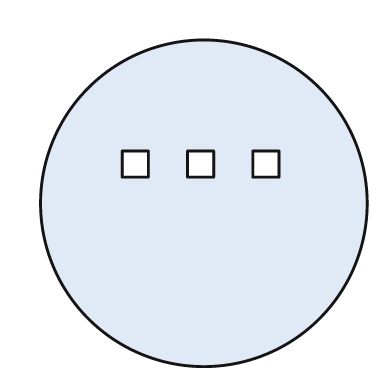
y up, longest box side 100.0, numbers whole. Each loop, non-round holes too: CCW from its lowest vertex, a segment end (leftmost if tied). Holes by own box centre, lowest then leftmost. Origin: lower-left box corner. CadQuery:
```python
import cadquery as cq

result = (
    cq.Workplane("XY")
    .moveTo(50.0, 50.0)
    .circle(50.0)
    .moveTo(25.0, 58.0)
    .lineTo(33.0, 58.0)
    .lineTo(33.0, 66.0)
    .lineTo(25.0, 66.0)
    .close()
    .moveTo(45.0, 58.0)
    .lineTo(53.0, 58.0)
    .lineTo(53.0, 66.0)
    .lineTo(45.0, 66.0)
    .close()
    .moveTo(65.0, 58.0)
    .lineTo(73.0, 58.0)
    .lineTo(73.0, 66.0)
    .lineTo(65.0, 66.0)
    .close()
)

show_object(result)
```